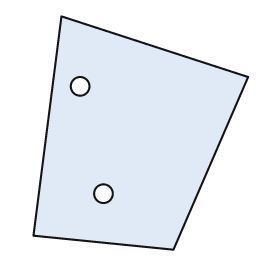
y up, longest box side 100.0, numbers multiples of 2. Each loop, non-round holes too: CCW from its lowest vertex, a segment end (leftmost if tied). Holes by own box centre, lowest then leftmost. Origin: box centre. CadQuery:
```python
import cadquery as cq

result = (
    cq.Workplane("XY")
    .moveTo(14.0, -50.0)
    .lineTo(46.0, 24.0)
    .lineTo(-34.0, 50.0)
    .lineTo(-46.0, -44.0)
    .close()
    .moveTo(-16.0, -26.0)
    .circle(4.0)
    .moveTo(-26.0, 20.0)
    .circle(4.0)
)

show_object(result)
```